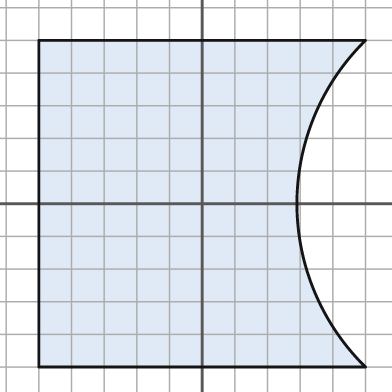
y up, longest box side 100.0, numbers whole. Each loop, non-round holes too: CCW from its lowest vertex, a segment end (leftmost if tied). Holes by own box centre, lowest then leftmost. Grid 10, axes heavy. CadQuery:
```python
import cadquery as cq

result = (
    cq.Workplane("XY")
    .moveTo(-50.0, -50.0)
    .lineTo(50.0, -50.0)
    .threePointArc((29.0, 0.0), (50.0, 50.0))
    .lineTo(-50.0, 50.0)
    .close()
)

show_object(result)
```